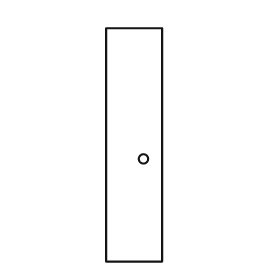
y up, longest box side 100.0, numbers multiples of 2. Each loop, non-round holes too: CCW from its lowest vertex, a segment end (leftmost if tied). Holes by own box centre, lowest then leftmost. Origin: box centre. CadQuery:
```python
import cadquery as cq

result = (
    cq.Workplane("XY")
    .moveTo(-12.0, -50.0)
    .lineTo(12.0, -50.0)
    .lineTo(12.0, 50.0)
    .lineTo(-12.0, 50.0)
    .close()
    .moveTo(4.0, -6.0)
    .circle(2.0)
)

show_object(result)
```